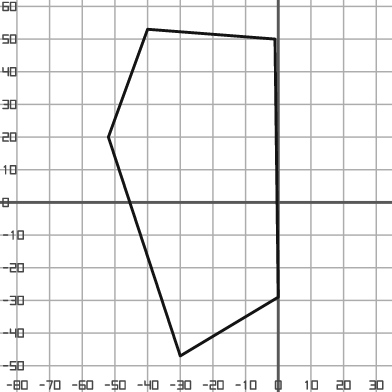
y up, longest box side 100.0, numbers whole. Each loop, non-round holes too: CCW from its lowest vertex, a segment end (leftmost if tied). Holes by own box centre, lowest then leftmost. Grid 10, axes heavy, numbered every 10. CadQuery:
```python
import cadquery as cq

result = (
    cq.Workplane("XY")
    .moveTo(-30.0, -47.0)
    .lineTo(0.0, -29.0)
    .lineTo(-1.0, 50.0)
    .lineTo(-40.0, 53.0)
    .lineTo(-52.0, 20.0)
    .close()
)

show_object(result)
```